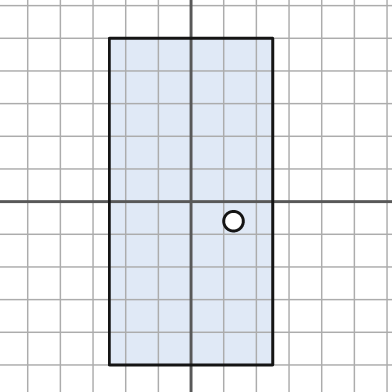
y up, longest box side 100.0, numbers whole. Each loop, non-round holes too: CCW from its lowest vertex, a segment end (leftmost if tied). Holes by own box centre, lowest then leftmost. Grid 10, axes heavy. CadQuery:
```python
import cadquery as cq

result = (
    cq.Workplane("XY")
    .moveTo(-25.0, -50.0)
    .lineTo(25.0, -50.0)
    .lineTo(25.0, 50.0)
    .lineTo(-25.0, 50.0)
    .close()
    .moveTo(13.0, -6.0)
    .circle(3.0)
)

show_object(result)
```